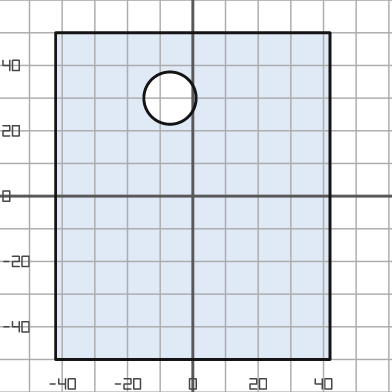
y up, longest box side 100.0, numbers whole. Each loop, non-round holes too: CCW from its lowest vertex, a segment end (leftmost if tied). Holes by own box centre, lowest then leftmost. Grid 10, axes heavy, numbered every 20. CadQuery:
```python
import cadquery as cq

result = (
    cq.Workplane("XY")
    .moveTo(-42.0, -50.0)
    .lineTo(42.0, -50.0)
    .lineTo(42.0, 50.0)
    .lineTo(-42.0, 50.0)
    .close()
    .moveTo(-7.0, 30.0)
    .circle(8.0)
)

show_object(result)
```